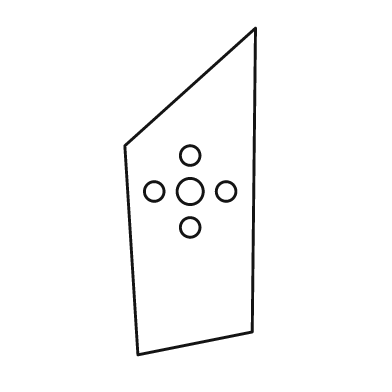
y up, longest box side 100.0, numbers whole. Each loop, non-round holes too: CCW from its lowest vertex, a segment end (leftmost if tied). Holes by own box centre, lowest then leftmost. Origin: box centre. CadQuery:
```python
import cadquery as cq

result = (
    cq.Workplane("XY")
    .moveTo(-16.0, -50.0)
    .lineTo(19.0, -43.0)
    .lineTo(20.0, 50.0)
    .lineTo(-20.0, 14.0)
    .close()
    .moveTo(0.0, -11.0)
    .circle(3.0)
    .moveTo(-11.0, 0.0)
    .circle(3.0)
    .moveTo(0.0, 0.0)
    .circle(4.0)
    .moveTo(11.0, 0.0)
    .circle(3.0)
    .moveTo(0.0, 11.0)
    .circle(3.0)
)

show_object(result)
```